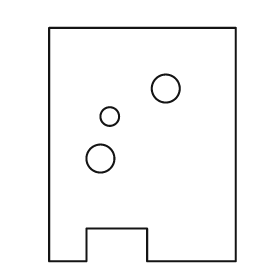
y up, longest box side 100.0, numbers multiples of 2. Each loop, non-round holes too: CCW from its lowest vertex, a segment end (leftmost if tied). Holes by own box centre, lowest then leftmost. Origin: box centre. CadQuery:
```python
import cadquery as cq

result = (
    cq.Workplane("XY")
    .moveTo(-40.0, -50.0)
    .lineTo(-24.0, -50.0)
    .lineTo(-24.0, -36.0)
    .lineTo(2.0, -36.0)
    .lineTo(2.0, -50.0)
    .lineTo(40.0, -50.0)
    .lineTo(40.0, 50.0)
    .lineTo(-40.0, 50.0)
    .close()
    .moveTo(-18.0, -6.0)
    .circle(6.0)
    .moveTo(-14.0, 12.0)
    .circle(4.0)
    .moveTo(10.0, 24.0)
    .circle(6.0)
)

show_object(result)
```